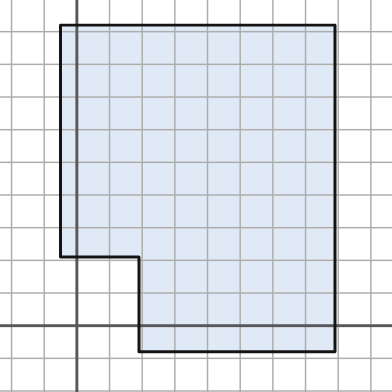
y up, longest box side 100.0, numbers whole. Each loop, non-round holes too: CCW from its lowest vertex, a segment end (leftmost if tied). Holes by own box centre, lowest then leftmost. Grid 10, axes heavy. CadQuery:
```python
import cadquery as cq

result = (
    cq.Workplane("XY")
    .moveTo(19.0, -8.0)
    .lineTo(79.0, -8.0)
    .lineTo(79.0, 92.0)
    .lineTo(-5.0, 92.0)
    .lineTo(-5.0, 21.0)
    .lineTo(19.0, 21.0)
    .close()
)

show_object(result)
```